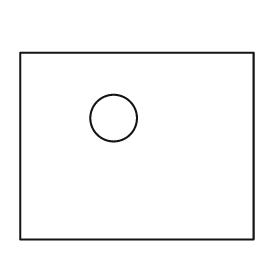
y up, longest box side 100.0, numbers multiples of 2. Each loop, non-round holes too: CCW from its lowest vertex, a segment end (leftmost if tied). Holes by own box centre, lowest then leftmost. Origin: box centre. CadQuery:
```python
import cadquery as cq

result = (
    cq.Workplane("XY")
    .moveTo(-50.0, -40.0)
    .lineTo(50.0, -40.0)
    .lineTo(50.0, 40.0)
    .lineTo(-50.0, 40.0)
    .close()
    .moveTo(-10.0, 12.0)
    .circle(10.0)
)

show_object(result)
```